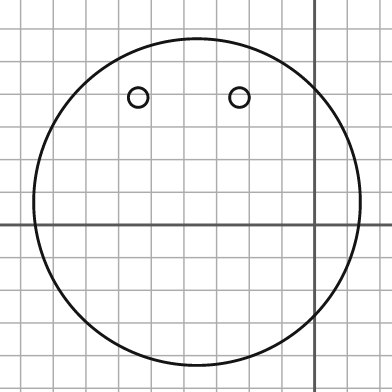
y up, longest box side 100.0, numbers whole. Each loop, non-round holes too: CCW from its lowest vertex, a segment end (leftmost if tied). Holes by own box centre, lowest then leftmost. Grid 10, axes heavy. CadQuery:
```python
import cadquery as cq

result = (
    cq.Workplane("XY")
    .moveTo(-36.0, 7.0)
    .circle(50.0)
    .moveTo(-54.0, 39.0)
    .circle(3.0)
    .moveTo(-23.0, 39.0)
    .circle(3.0)
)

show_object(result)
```